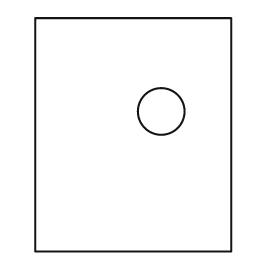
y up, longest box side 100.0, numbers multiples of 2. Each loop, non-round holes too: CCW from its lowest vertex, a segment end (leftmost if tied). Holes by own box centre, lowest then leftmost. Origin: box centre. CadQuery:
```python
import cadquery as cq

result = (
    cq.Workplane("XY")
    .moveTo(-42.0, -50.0)
    .lineTo(42.0, -50.0)
    .lineTo(42.0, 50.0)
    .lineTo(-42.0, 50.0)
    .close()
    .moveTo(12.0, 10.0)
    .circle(10.0)
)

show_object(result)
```